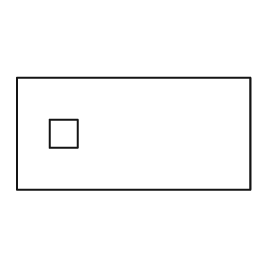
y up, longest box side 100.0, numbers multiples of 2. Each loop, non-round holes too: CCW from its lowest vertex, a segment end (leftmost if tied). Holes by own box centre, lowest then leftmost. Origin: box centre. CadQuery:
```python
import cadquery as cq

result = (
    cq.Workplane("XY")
    .moveTo(-50.0, -24.0)
    .lineTo(50.0, -24.0)
    .lineTo(50.0, 24.0)
    .lineTo(-50.0, 24.0)
    .close()
    .moveTo(-36.0, -6.0)
    .lineTo(-24.0, -6.0)
    .lineTo(-24.0, 6.0)
    .lineTo(-36.0, 6.0)
    .close()
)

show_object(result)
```